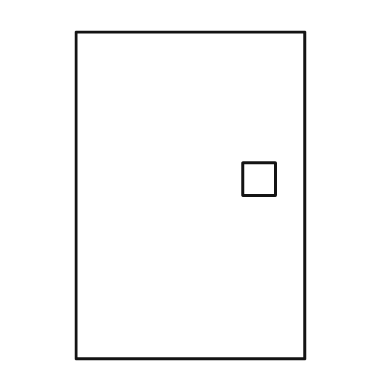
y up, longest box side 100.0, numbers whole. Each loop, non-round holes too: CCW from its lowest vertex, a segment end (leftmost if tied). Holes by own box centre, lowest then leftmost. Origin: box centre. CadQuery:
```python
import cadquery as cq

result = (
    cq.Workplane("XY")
    .moveTo(-35.0, -50.0)
    .lineTo(35.0, -50.0)
    .lineTo(35.0, 50.0)
    .lineTo(-35.0, 50.0)
    .close()
    .moveTo(16.0, 0.0)
    .lineTo(26.0, 0.0)
    .lineTo(26.0, 10.0)
    .lineTo(16.0, 10.0)
    .close()
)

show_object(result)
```